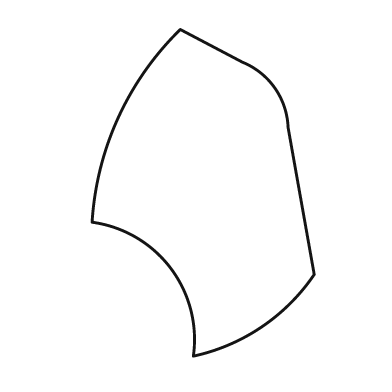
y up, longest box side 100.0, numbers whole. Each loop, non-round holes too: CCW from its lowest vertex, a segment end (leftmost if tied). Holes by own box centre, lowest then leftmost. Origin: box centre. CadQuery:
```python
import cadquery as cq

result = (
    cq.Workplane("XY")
    .moveTo(-3.0, -50.0)
    .threePointArc((18.0, -41.0), (34.0, -25.0))
    .lineTo(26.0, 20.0)
    .threePointArc((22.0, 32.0), (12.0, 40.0))
    .lineTo(-7.0, 50.0)
    .threePointArc((-26.0, 23.0), (-34.0, -9.0))
    .threePointArc((-10.0, -23.0), (-3.0, -50.0))
    .close()
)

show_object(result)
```